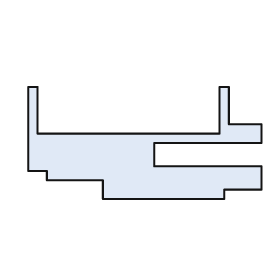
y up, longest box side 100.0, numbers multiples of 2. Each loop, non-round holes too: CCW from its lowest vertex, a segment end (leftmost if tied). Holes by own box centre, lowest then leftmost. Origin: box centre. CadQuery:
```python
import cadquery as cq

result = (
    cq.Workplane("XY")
    .moveTo(-18.0, -24.0)
    .lineTo(34.0, -24.0)
    .lineTo(34.0, -20.0)
    .lineTo(50.0, -20.0)
    .lineTo(50.0, -10.0)
    .lineTo(4.0, -10.0)
    .lineTo(4.0, 0.0)
    .lineTo(50.0, 0.0)
    .lineTo(50.0, 8.0)
    .lineTo(36.0, 8.0)
    .lineTo(36.0, 24.0)
    .lineTo(32.0, 24.0)
    .lineTo(32.0, 4.0)
    .lineTo(-46.0, 4.0)
    .lineTo(-46.0, 24.0)
    .lineTo(-50.0, 24.0)
    .lineTo(-50.0, -12.0)
    .lineTo(-42.0, -12.0)
    .lineTo(-42.0, -16.0)
    .lineTo(-18.0, -16.0)
    .close()
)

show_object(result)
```